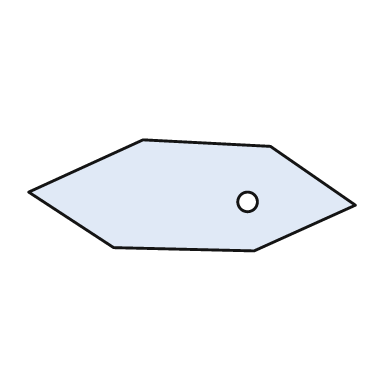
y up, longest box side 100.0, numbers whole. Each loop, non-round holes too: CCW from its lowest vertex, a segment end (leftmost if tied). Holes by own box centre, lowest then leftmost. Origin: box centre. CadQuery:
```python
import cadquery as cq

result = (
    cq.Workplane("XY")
    .moveTo(19.0, -17.0)
    .lineTo(50.0, -3.0)
    .lineTo(24.0, 15.0)
    .lineTo(-15.0, 17.0)
    .lineTo(-50.0, 1.0)
    .lineTo(-24.0, -16.0)
    .close()
    .moveTo(17.0, -2.0)
    .circle(3.0)
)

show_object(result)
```